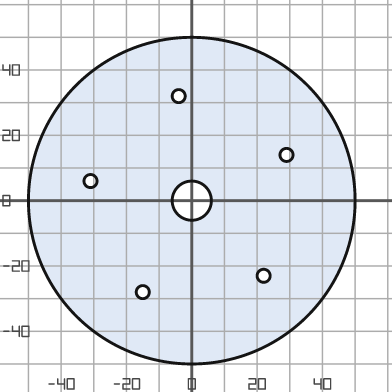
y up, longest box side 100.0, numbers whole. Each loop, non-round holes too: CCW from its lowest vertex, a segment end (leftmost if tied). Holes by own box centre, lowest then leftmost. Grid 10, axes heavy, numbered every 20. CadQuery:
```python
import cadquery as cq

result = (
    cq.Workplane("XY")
    .moveTo(0.0, 0.0)
    .circle(50.0)
    .moveTo(-15.0, -28.0)
    .circle(2.0)
    .moveTo(22.0, -23.0)
    .circle(2.0)
    .moveTo(0.0, 0.0)
    .circle(6.0)
    .moveTo(-31.0, 6.0)
    .circle(2.0)
    .moveTo(29.0, 14.0)
    .circle(2.0)
    .moveTo(-4.0, 32.0)
    .circle(2.0)
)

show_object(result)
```